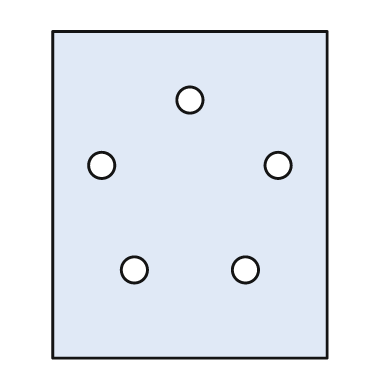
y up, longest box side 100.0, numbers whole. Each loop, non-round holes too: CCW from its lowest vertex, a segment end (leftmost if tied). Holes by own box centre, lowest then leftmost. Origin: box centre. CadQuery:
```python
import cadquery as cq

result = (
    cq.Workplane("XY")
    .moveTo(-42.0, -50.0)
    .lineTo(42.0, -50.0)
    .lineTo(42.0, 50.0)
    .lineTo(-42.0, 50.0)
    .close()
    .moveTo(-17.0, -23.0)
    .circle(4.0)
    .moveTo(17.0, -23.0)
    .circle(4.0)
    .moveTo(-27.0, 9.0)
    .circle(4.0)
    .moveTo(27.0, 9.0)
    .circle(4.0)
    .moveTo(0.0, 29.0)
    .circle(4.0)
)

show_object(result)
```